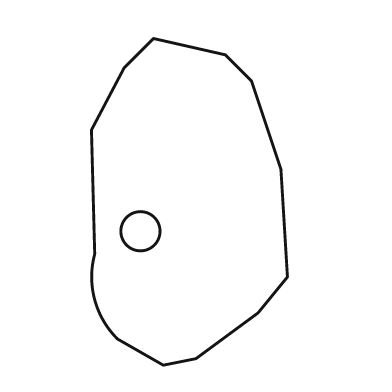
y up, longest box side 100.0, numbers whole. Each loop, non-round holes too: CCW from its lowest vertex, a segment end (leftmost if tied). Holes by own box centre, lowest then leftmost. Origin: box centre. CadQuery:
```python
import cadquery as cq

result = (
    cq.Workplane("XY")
    .moveTo(-8.0, -50.0)
    .lineTo(2.0, -48.0)
    .lineTo(21.0, -34.0)
    .lineTo(30.0, -23.0)
    .lineTo(28.0, 10.0)
    .lineTo(19.0, 37.0)
    .lineTo(11.0, 45.0)
    .lineTo(-11.0, 50.0)
    .lineTo(-20.0, 41.0)
    .lineTo(-30.0, 22.0)
    .lineTo(-29.0, -16.0)
    .threePointArc((-29.0, -30.0), (-22.0, -42.0))
    .close()
    .moveTo(-15.0, -9.0)
    .circle(6.0)
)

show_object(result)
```